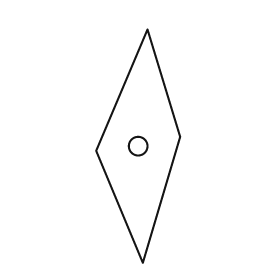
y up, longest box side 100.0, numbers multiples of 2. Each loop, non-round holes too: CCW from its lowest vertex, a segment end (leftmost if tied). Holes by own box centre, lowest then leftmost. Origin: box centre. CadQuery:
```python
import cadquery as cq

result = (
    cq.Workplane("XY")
    .moveTo(2.0, -50.0)
    .lineTo(18.0, 4.0)
    .lineTo(4.0, 50.0)
    .lineTo(-18.0, -2.0)
    .close()
    .moveTo(0.0, 0.0)
    .circle(4.0)
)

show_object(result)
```